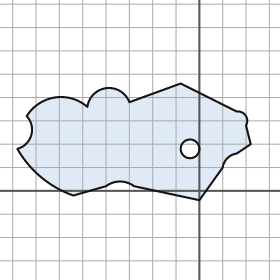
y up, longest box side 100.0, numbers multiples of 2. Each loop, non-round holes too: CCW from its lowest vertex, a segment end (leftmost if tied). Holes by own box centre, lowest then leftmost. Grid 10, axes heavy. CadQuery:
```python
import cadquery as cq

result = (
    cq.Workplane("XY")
    .moveTo(0.0, -4.0)
    .lineTo(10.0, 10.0)
    .threePointArc((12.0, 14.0), (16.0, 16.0))
    .lineTo(22.0, 20.0)
    .lineTo(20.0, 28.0)
    .threePointArc((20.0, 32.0), (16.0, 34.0))
    .lineTo(-8.0, 46.0)
    .lineTo(-30.0, 38.0)
    .threePointArc((-40.0, 44.0), (-48.0, 36.0))
    .threePointArc((-62.0, 40.0), (-74.0, 32.0))
    .threePointArc((-72.0, 24.0), (-78.0, 18.0))
    .threePointArc((-68.0, 6.0), (-54.0, -2.0))
    .lineTo(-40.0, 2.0)
    .threePointArc((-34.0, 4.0), (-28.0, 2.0))
    .close()
    .moveTo(-4.0, 18.0)
    .circle(4.0)
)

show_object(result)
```